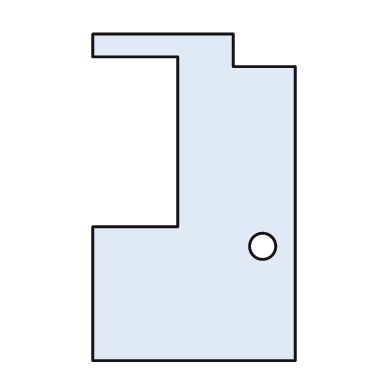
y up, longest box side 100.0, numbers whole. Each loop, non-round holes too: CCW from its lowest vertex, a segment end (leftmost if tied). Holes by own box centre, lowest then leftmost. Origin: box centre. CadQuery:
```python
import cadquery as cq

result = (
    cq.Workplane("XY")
    .moveTo(-31.0, -50.0)
    .lineTo(31.0, -50.0)
    .lineTo(31.0, 40.0)
    .lineTo(12.0, 40.0)
    .lineTo(12.0, 50.0)
    .lineTo(-31.0, 50.0)
    .lineTo(-31.0, 43.0)
    .lineTo(-5.0, 43.0)
    .lineTo(-5.0, -9.0)
    .lineTo(-31.0, -9.0)
    .close()
    .moveTo(21.0, -15.0)
    .circle(4.0)
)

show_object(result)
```